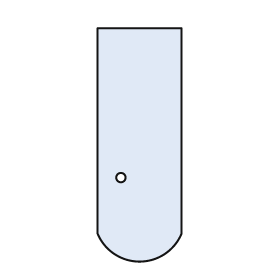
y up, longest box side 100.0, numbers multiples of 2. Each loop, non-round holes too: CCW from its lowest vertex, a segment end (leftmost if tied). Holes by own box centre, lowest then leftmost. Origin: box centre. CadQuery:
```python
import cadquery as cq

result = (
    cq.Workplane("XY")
    .moveTo(-18.0, -38.0)
    .threePointArc((0.0, -50.0), (18.0, -38.0))
    .lineTo(18.0, 50.0)
    .lineTo(-18.0, 50.0)
    .close()
    .moveTo(-8.0, -14.0)
    .circle(2.0)
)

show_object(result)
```